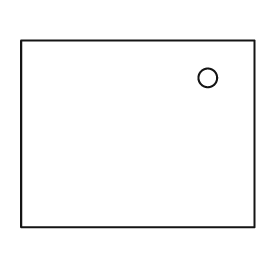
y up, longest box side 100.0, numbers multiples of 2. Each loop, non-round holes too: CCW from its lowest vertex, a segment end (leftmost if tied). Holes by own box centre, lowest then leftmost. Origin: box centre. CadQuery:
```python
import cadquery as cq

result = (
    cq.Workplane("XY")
    .moveTo(-50.0, -40.0)
    .lineTo(50.0, -40.0)
    .lineTo(50.0, 40.0)
    .lineTo(-50.0, 40.0)
    .close()
    .moveTo(30.0, 24.0)
    .circle(4.0)
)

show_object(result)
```